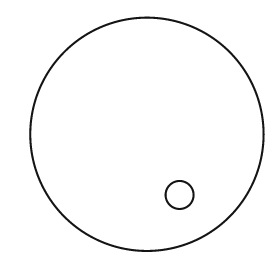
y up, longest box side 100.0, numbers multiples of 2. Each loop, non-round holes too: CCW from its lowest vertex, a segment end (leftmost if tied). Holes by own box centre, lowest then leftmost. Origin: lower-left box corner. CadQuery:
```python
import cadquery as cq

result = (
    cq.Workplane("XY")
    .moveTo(50.0, 50.0)
    .circle(50.0)
    .moveTo(64.0, 24.0)
    .circle(6.0)
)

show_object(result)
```